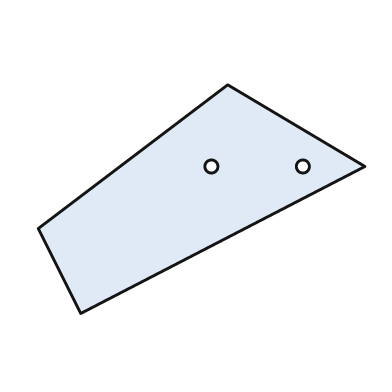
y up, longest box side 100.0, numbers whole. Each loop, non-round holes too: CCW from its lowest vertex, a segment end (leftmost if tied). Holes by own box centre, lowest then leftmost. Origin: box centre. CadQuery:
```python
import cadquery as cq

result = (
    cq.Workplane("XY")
    .moveTo(-37.0, -35.0)
    .lineTo(50.0, 10.0)
    .lineTo(8.0, 35.0)
    .lineTo(-50.0, -9.0)
    .close()
    .moveTo(3.0, 10.0)
    .circle(2.0)
    .moveTo(31.0, 10.0)
    .circle(2.0)
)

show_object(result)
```